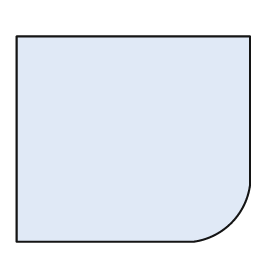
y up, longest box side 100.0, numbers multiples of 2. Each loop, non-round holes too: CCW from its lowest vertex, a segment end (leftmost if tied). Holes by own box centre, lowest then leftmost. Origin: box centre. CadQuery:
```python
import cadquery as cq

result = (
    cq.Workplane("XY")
    .moveTo(-50.0, -44.0)
    .lineTo(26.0, -44.0)
    .threePointArc((42.0, -36.0), (50.0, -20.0))
    .lineTo(50.0, 44.0)
    .lineTo(-50.0, 44.0)
    .close()
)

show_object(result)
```